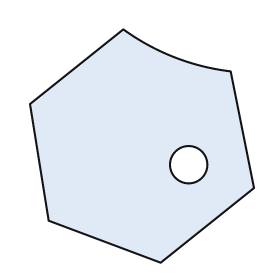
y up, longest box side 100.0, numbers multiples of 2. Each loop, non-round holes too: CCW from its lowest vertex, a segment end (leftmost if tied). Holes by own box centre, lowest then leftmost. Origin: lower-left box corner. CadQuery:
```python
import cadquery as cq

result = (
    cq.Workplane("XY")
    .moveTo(56.0, 0.0)
    .lineTo(96.0, 32.0)
    .lineTo(86.0, 82.0)
    .threePointArc((62.0, 88.0), (40.0, 100.0))
    .lineTo(0.0, 68.0)
    .lineTo(8.0, 18.0)
    .close()
    .moveTo(68.0, 42.0)
    .circle(8.0)
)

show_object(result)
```